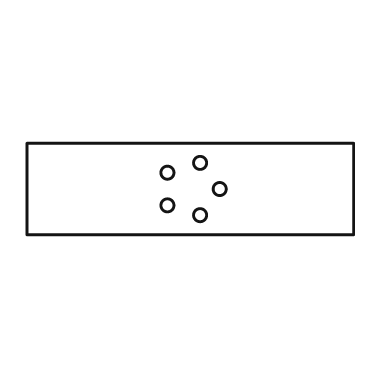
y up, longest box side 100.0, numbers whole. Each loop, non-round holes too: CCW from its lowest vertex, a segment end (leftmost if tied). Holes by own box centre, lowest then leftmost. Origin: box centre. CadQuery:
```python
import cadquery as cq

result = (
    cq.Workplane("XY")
    .moveTo(-50.0, -14.0)
    .lineTo(50.0, -14.0)
    .lineTo(50.0, 14.0)
    .lineTo(-50.0, 14.0)
    .close()
    .moveTo(3.0, -8.0)
    .circle(2.0)
    .moveTo(-7.0, -5.0)
    .circle(2.0)
    .moveTo(9.0, 0.0)
    .circle(2.0)
    .moveTo(-7.0, 5.0)
    .circle(2.0)
    .moveTo(3.0, 8.0)
    .circle(2.0)
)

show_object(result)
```